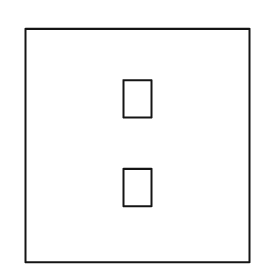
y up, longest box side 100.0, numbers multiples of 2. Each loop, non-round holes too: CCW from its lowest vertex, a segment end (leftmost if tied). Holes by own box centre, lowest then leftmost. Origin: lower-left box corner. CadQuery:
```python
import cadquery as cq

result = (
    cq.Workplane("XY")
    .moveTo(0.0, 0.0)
    .lineTo(96.0, 0.0)
    .lineTo(96.0, 100.0)
    .lineTo(0.0, 100.0)
    .close()
    .moveTo(42.0, 24.0)
    .lineTo(54.0, 24.0)
    .lineTo(54.0, 40.0)
    .lineTo(42.0, 40.0)
    .close()
    .moveTo(42.0, 62.0)
    .lineTo(54.0, 62.0)
    .lineTo(54.0, 78.0)
    .lineTo(42.0, 78.0)
    .close()
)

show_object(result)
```